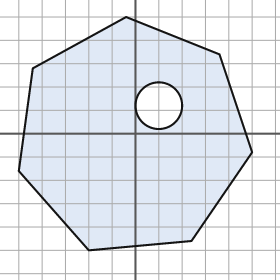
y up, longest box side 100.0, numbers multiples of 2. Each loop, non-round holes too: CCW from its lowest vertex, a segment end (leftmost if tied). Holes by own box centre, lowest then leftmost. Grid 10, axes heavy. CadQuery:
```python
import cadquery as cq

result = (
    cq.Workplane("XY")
    .moveTo(-20.0, -50.0)
    .lineTo(24.0, -46.0)
    .lineTo(50.0, -8.0)
    .lineTo(36.0, 34.0)
    .lineTo(-4.0, 50.0)
    .lineTo(-44.0, 28.0)
    .lineTo(-50.0, -16.0)
    .close()
    .moveTo(10.0, 12.0)
    .circle(10.0)
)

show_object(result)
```